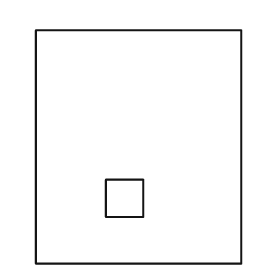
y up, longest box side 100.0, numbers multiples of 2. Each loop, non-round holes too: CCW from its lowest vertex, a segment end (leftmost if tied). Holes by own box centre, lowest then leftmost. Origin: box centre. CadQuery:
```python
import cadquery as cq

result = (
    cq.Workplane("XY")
    .moveTo(-44.0, -50.0)
    .lineTo(44.0, -50.0)
    .lineTo(44.0, 50.0)
    .lineTo(-44.0, 50.0)
    .close()
    .moveTo(-14.0, -30.0)
    .lineTo(2.0, -30.0)
    .lineTo(2.0, -14.0)
    .lineTo(-14.0, -14.0)
    .close()
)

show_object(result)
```